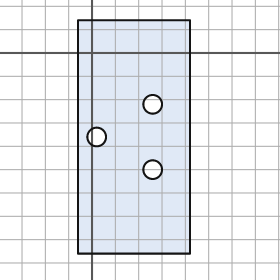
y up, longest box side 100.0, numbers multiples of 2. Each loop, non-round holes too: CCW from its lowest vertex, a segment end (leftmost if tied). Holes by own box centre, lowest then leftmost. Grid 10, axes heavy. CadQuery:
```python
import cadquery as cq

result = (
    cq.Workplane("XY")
    .moveTo(-6.0, -86.0)
    .lineTo(42.0, -86.0)
    .lineTo(42.0, 14.0)
    .lineTo(-6.0, 14.0)
    .close()
    .moveTo(26.0, -50.0)
    .circle(4.0)
    .moveTo(2.0, -36.0)
    .circle(4.0)
    .moveTo(26.0, -22.0)
    .circle(4.0)
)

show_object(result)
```